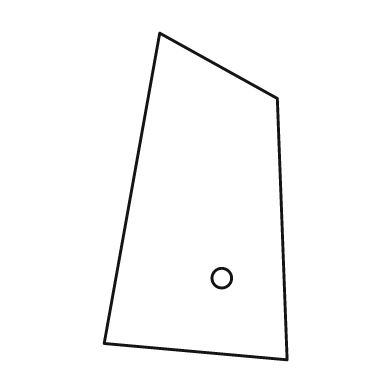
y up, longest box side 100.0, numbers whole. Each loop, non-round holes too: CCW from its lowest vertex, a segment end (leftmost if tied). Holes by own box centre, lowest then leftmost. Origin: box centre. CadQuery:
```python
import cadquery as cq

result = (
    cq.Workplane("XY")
    .moveTo(28.0, -50.0)
    .lineTo(25.0, 30.0)
    .lineTo(-11.0, 50.0)
    .lineTo(-28.0, -45.0)
    .close()
    .moveTo(8.0, -25.0)
    .circle(3.0)
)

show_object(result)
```